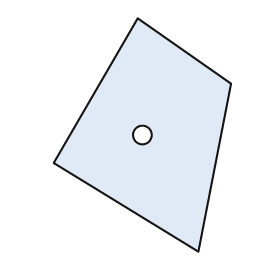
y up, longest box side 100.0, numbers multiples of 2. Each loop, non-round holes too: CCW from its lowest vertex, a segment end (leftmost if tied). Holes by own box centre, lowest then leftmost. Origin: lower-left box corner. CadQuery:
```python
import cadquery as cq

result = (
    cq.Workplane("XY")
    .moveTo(62.0, 0.0)
    .lineTo(76.0, 72.0)
    .lineTo(36.0, 100.0)
    .lineTo(0.0, 38.0)
    .close()
    .moveTo(38.0, 50.0)
    .circle(4.0)
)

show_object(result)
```